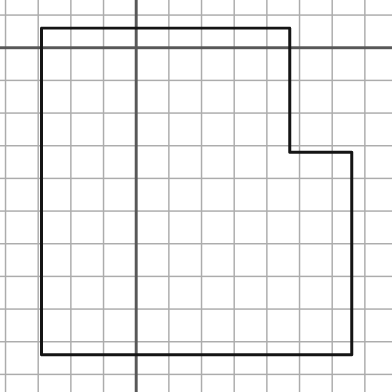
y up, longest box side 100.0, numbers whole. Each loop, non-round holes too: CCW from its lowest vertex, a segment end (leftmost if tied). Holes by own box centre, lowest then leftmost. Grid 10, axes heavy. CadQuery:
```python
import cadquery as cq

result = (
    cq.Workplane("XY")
    .moveTo(-29.0, -94.0)
    .lineTo(66.0, -94.0)
    .lineTo(66.0, -32.0)
    .lineTo(47.0, -32.0)
    .lineTo(47.0, 6.0)
    .lineTo(-29.0, 6.0)
    .close()
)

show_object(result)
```